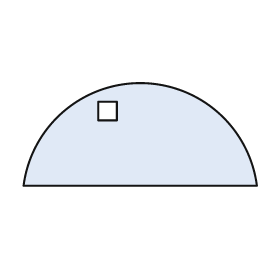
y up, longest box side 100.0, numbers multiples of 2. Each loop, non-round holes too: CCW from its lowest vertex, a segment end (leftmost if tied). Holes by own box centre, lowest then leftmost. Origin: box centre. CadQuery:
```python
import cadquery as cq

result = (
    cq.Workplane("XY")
    .moveTo(-50.0, -22.0)
    .lineTo(50.0, -22.0)
    .threePointArc((0.0, 22.0), (-50.0, -22.0))
    .close()
    .moveTo(-18.0, 6.0)
    .lineTo(-10.0, 6.0)
    .lineTo(-10.0, 14.0)
    .lineTo(-18.0, 14.0)
    .close()
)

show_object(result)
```